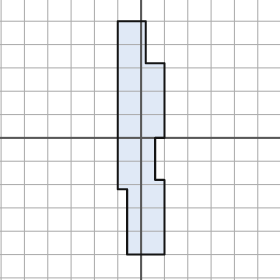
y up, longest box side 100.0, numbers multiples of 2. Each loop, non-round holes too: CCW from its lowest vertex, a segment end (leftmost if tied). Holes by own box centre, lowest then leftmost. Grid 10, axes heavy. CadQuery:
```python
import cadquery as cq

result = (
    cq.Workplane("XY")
    .moveTo(-6.0, -50.0)
    .lineTo(10.0, -50.0)
    .lineTo(10.0, -18.0)
    .lineTo(6.0, -18.0)
    .lineTo(6.0, 0.0)
    .lineTo(10.0, 0.0)
    .lineTo(10.0, 32.0)
    .lineTo(2.0, 32.0)
    .lineTo(2.0, 50.0)
    .lineTo(-10.0, 50.0)
    .lineTo(-10.0, -22.0)
    .lineTo(-6.0, -22.0)
    .close()
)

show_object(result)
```